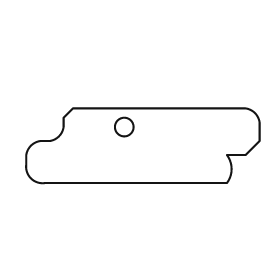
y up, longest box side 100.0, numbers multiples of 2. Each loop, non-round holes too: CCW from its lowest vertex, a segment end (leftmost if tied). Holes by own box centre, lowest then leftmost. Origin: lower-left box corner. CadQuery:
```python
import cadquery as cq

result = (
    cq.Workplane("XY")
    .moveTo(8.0, 0.0)
    .lineTo(86.0, 0.0)
    .threePointArc((88.0, 6.0), (86.0, 12.0))
    .lineTo(94.0, 12.0)
    .lineTo(100.0, 18.0)
    .lineTo(100.0, 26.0)
    .threePointArc((98.0, 30.0), (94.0, 32.0))
    .lineTo(20.0, 32.0)
    .lineTo(16.0, 28.0)
    .lineTo(16.0, 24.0)
    .threePointArc((14.0, 20.0), (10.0, 18.0))
    .lineTo(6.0, 18.0)
    .threePointArc((2.0, 16.0), (0.0, 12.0))
    .lineTo(0.0, 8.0)
    .threePointArc((2.0, 2.0), (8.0, 0.0))
    .close()
    .moveTo(42.0, 24.0)
    .circle(4.0)
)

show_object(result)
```